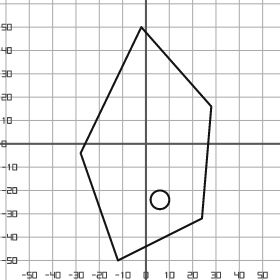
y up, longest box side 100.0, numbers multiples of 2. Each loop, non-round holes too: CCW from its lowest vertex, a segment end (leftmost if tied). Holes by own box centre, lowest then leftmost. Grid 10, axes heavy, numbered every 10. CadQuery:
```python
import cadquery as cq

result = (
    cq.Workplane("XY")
    .moveTo(-12.0, -50.0)
    .lineTo(24.0, -32.0)
    .lineTo(28.0, 16.0)
    .lineTo(-2.0, 50.0)
    .lineTo(-28.0, -4.0)
    .close()
    .moveTo(6.0, -24.0)
    .circle(4.0)
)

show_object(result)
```